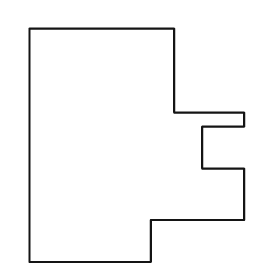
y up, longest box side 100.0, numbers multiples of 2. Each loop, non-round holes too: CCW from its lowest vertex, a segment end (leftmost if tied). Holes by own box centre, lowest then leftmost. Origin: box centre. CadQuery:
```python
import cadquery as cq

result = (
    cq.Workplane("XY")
    .moveTo(-46.0, -50.0)
    .lineTo(6.0, -50.0)
    .lineTo(6.0, -32.0)
    .lineTo(46.0, -32.0)
    .lineTo(46.0, -10.0)
    .lineTo(28.0, -10.0)
    .lineTo(28.0, 8.0)
    .lineTo(46.0, 8.0)
    .lineTo(46.0, 14.0)
    .lineTo(16.0, 14.0)
    .lineTo(16.0, 50.0)
    .lineTo(-46.0, 50.0)
    .close()
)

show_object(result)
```